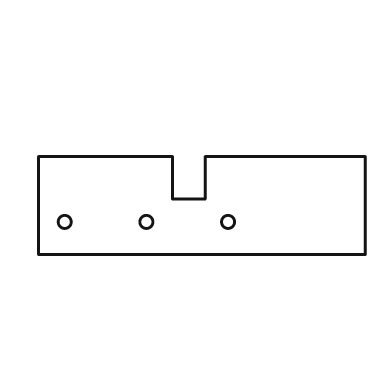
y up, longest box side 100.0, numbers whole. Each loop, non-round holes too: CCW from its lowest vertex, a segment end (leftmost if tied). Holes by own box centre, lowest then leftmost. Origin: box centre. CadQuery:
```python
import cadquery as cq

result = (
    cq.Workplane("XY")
    .moveTo(-50.0, -15.0)
    .lineTo(50.0, -15.0)
    .lineTo(50.0, 15.0)
    .lineTo(1.0, 15.0)
    .lineTo(1.0, 2.0)
    .lineTo(-9.0, 2.0)
    .lineTo(-9.0, 15.0)
    .lineTo(-50.0, 15.0)
    .close()
    .moveTo(-42.0, -5.0)
    .circle(2.0)
    .moveTo(-17.0, -5.0)
    .circle(2.0)
    .moveTo(8.0, -5.0)
    .circle(2.0)
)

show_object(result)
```